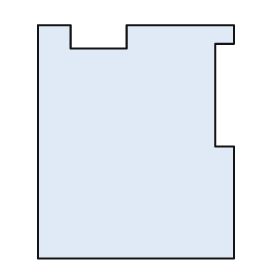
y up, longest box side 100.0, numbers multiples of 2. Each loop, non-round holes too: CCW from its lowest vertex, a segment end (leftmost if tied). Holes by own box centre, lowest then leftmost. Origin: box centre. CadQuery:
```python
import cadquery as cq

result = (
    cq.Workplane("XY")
    .moveTo(-42.0, -50.0)
    .lineTo(42.0, -50.0)
    .lineTo(42.0, -2.0)
    .lineTo(34.0, -2.0)
    .lineTo(34.0, 42.0)
    .lineTo(42.0, 42.0)
    .lineTo(42.0, 50.0)
    .lineTo(-4.0, 50.0)
    .lineTo(-4.0, 40.0)
    .lineTo(-28.0, 40.0)
    .lineTo(-28.0, 50.0)
    .lineTo(-42.0, 50.0)
    .close()
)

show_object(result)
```